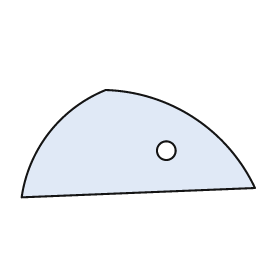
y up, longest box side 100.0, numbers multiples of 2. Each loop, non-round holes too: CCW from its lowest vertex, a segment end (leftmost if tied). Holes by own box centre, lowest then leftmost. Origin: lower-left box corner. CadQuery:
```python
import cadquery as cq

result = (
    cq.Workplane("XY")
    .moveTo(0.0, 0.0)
    .lineTo(100.0, 4.0)
    .threePointArc((74.0, 34.0), (36.0, 46.0))
    .threePointArc((12.0, 28.0), (0.0, 0.0))
    .close()
    .moveTo(62.0, 20.0)
    .circle(4.0)
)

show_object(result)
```